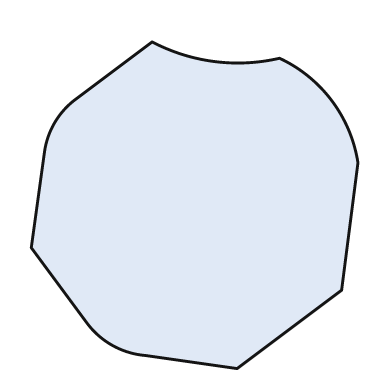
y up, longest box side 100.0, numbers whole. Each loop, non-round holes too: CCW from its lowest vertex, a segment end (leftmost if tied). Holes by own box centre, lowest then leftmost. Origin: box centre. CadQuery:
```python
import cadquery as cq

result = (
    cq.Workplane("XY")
    .moveTo(13.0, -50.0)
    .lineTo(45.0, -26.0)
    .lineTo(50.0, 13.0)
    .threePointArc((42.0, 32.0), (26.0, 45.0))
    .threePointArc((6.0, 44.0), (-13.0, 50.0))
    .lineTo(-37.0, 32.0)
    .threePointArc((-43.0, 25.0), (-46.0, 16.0))
    .lineTo(-50.0, -13.0)
    .lineTo(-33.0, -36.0)
    .threePointArc((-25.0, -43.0), (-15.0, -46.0))
    .close()
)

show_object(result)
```